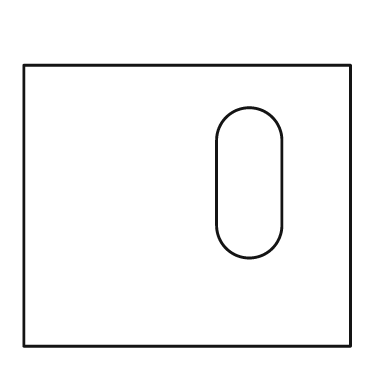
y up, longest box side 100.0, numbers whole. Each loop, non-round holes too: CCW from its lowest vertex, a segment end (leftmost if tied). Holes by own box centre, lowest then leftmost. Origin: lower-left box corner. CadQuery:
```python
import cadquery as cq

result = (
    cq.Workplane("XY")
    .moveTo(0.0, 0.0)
    .lineTo(100.0, 0.0)
    .lineTo(100.0, 86.0)
    .lineTo(0.0, 86.0)
    .close()
    .moveTo(59.0, 37.0)
    .threePointArc((69.0, 27.0), (79.0, 37.0))
    .lineTo(79.0, 63.0)
    .threePointArc((69.0, 73.0), (59.0, 63.0))
    .close()
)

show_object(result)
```